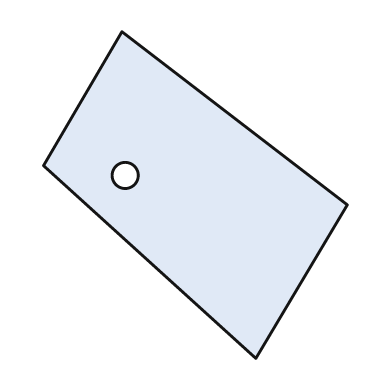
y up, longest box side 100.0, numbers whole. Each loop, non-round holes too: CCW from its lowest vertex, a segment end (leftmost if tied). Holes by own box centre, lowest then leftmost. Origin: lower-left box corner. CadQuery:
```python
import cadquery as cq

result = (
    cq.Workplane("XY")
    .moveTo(65.0, 0.0)
    .lineTo(93.0, 47.0)
    .lineTo(24.0, 100.0)
    .lineTo(0.0, 59.0)
    .close()
    .moveTo(25.0, 56.0)
    .circle(4.0)
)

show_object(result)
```